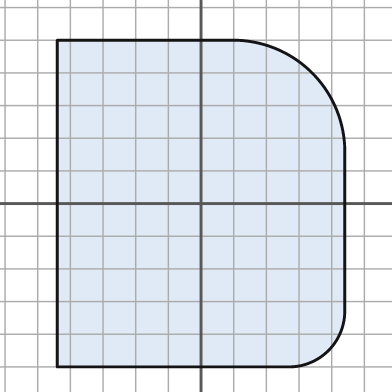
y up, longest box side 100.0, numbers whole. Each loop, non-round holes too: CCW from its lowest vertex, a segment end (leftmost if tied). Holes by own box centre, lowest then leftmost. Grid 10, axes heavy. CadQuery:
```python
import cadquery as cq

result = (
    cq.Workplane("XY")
    .moveTo(-44.0, -50.0)
    .lineTo(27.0, -50.0)
    .threePointArc((39.0, -45.0), (44.0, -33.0))
    .lineTo(44.0, 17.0)
    .threePointArc((34.0, 40.0), (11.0, 50.0))
    .lineTo(-44.0, 50.0)
    .close()
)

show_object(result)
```